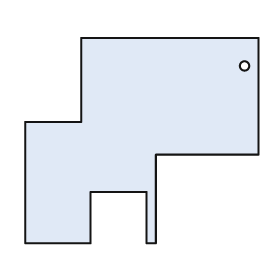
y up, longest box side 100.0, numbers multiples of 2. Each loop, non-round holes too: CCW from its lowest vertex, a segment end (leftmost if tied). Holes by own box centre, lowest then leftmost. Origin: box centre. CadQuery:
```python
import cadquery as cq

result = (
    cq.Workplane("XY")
    .moveTo(-50.0, -44.0)
    .lineTo(-22.0, -44.0)
    .lineTo(-22.0, -22.0)
    .lineTo(2.0, -22.0)
    .lineTo(2.0, -44.0)
    .lineTo(6.0, -44.0)
    .lineTo(6.0, -6.0)
    .lineTo(50.0, -6.0)
    .lineTo(50.0, 44.0)
    .lineTo(-26.0, 44.0)
    .lineTo(-26.0, 8.0)
    .lineTo(-50.0, 8.0)
    .close()
    .moveTo(44.0, 32.0)
    .circle(2.0)
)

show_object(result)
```